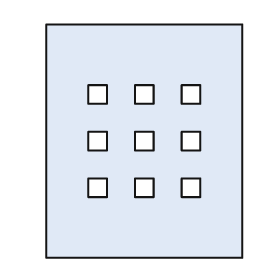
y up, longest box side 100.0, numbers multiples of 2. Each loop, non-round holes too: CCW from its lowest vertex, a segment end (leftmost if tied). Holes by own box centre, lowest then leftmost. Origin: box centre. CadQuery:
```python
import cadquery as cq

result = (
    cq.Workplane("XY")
    .moveTo(-42.0, -50.0)
    .lineTo(42.0, -50.0)
    .lineTo(42.0, 50.0)
    .lineTo(-42.0, 50.0)
    .close()
    .moveTo(-24.0, -24.0)
    .lineTo(-16.0, -24.0)
    .lineTo(-16.0, -16.0)
    .lineTo(-24.0, -16.0)
    .close()
    .moveTo(-4.0, -24.0)
    .lineTo(4.0, -24.0)
    .lineTo(4.0, -16.0)
    .lineTo(-4.0, -16.0)
    .close()
    .moveTo(16.0, -24.0)
    .lineTo(24.0, -24.0)
    .lineTo(24.0, -16.0)
    .lineTo(16.0, -16.0)
    .close()
    .moveTo(-24.0, -4.0)
    .lineTo(-16.0, -4.0)
    .lineTo(-16.0, 4.0)
    .lineTo(-24.0, 4.0)
    .close()
    .moveTo(-4.0, -4.0)
    .lineTo(4.0, -4.0)
    .lineTo(4.0, 4.0)
    .lineTo(-4.0, 4.0)
    .close()
    .moveTo(16.0, -4.0)
    .lineTo(24.0, -4.0)
    .lineTo(24.0, 4.0)
    .lineTo(16.0, 4.0)
    .close()
    .moveTo(-24.0, 16.0)
    .lineTo(-16.0, 16.0)
    .lineTo(-16.0, 24.0)
    .lineTo(-24.0, 24.0)
    .close()
    .moveTo(-4.0, 16.0)
    .lineTo(4.0, 16.0)
    .lineTo(4.0, 24.0)
    .lineTo(-4.0, 24.0)
    .close()
    .moveTo(16.0, 16.0)
    .lineTo(24.0, 16.0)
    .lineTo(24.0, 24.0)
    .lineTo(16.0, 24.0)
    .close()
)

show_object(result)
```